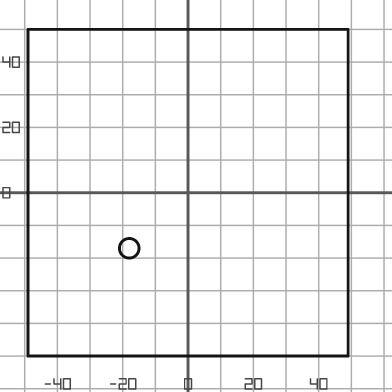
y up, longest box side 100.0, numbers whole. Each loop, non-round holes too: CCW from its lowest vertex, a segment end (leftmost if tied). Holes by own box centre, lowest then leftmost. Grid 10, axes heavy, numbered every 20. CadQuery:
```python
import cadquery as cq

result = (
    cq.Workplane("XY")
    .moveTo(-49.0, -50.0)
    .lineTo(49.0, -50.0)
    .lineTo(49.0, 50.0)
    .lineTo(-49.0, 50.0)
    .close()
    .moveTo(-18.0, -17.0)
    .circle(3.0)
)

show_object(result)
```